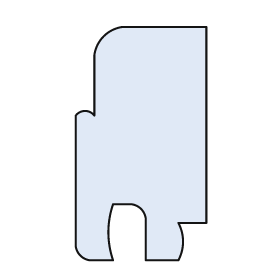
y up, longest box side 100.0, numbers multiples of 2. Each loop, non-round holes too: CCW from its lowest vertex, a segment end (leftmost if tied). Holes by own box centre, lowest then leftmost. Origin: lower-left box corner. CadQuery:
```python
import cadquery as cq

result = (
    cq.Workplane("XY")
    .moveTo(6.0, 0.0)
    .lineTo(16.0, 0.0)
    .threePointArc((14.0, 12.0), (16.0, 24.0))
    .lineTo(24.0, 24.0)
    .threePointArc((28.0, 22.0), (30.0, 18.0))
    .lineTo(30.0, 0.0)
    .lineTo(44.0, 0.0)
    .threePointArc((46.0, 8.0), (44.0, 16.0))
    .lineTo(56.0, 16.0)
    .lineTo(56.0, 100.0)
    .lineTo(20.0, 100.0)
    .threePointArc((12.0, 96.0), (8.0, 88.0))
    .lineTo(8.0, 62.0)
    .threePointArc((4.0, 64.0), (0.0, 62.0))
    .lineTo(0.0, 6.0)
    .threePointArc((2.0, 2.0), (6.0, 0.0))
    .close()
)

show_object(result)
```